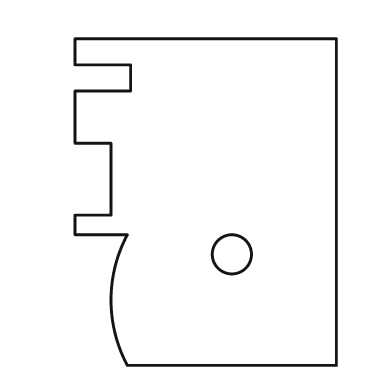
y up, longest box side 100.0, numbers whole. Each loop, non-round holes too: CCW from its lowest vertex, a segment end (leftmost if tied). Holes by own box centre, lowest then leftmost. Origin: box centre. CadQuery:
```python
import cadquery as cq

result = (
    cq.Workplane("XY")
    .moveTo(-24.0, -50.0)
    .lineTo(40.0, -50.0)
    .lineTo(40.0, 50.0)
    .lineTo(-40.0, 50.0)
    .lineTo(-40.0, 42.0)
    .lineTo(-23.0, 42.0)
    .lineTo(-23.0, 34.0)
    .lineTo(-40.0, 34.0)
    .lineTo(-40.0, 18.0)
    .lineTo(-29.0, 18.0)
    .lineTo(-29.0, -4.0)
    .lineTo(-40.0, -4.0)
    .lineTo(-40.0, -10.0)
    .lineTo(-24.0, -10.0)
    .threePointArc((-29.0, -30.0), (-24.0, -50.0))
    .close()
    .moveTo(8.0, -16.0)
    .circle(6.0)
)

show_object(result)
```